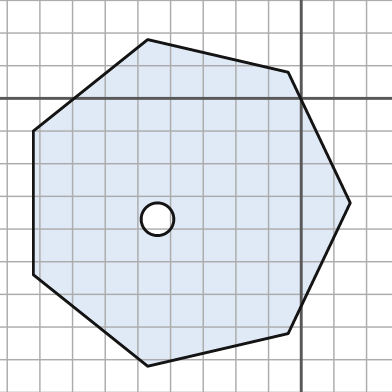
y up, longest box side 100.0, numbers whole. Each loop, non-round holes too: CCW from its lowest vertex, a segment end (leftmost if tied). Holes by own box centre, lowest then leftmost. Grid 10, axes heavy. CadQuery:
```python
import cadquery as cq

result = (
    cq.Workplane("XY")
    .moveTo(-47.0, -82.0)
    .lineTo(-4.0, -72.0)
    .lineTo(15.0, -32.0)
    .lineTo(-4.0, 8.0)
    .lineTo(-47.0, 18.0)
    .lineTo(-82.0, -10.0)
    .lineTo(-82.0, -54.0)
    .close()
    .moveTo(-44.0, -37.0)
    .circle(5.0)
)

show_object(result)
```